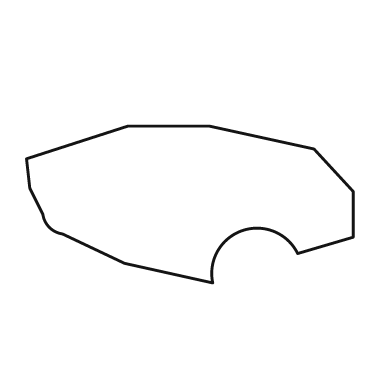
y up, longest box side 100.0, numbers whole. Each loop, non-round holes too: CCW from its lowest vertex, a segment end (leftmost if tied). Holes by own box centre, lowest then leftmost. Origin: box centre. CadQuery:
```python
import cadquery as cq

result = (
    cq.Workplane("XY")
    .moveTo(7.0, -24.0)
    .threePointArc((16.0, -8.0), (33.0, -15.0))
    .lineTo(50.0, -10.0)
    .lineTo(50.0, 4.0)
    .lineTo(38.0, 17.0)
    .lineTo(6.0, 24.0)
    .lineTo(-19.0, 24.0)
    .lineTo(-50.0, 14.0)
    .lineTo(-49.0, 5.0)
    .lineTo(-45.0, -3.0)
    .threePointArc((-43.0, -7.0), (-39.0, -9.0))
    .lineTo(-20.0, -18.0)
    .close()
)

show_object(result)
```